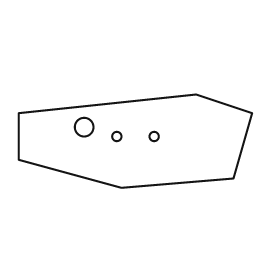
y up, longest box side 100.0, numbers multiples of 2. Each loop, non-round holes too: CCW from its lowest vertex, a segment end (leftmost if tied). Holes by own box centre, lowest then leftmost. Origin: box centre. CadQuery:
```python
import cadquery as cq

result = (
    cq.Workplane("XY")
    .moveTo(-6.0, -20.0)
    .lineTo(42.0, -16.0)
    .lineTo(50.0, 12.0)
    .lineTo(26.0, 20.0)
    .lineTo(-50.0, 12.0)
    .lineTo(-50.0, -8.0)
    .close()
    .moveTo(-8.0, 2.0)
    .circle(2.0)
    .moveTo(8.0, 2.0)
    .circle(2.0)
    .moveTo(-22.0, 6.0)
    .circle(4.0)
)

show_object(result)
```